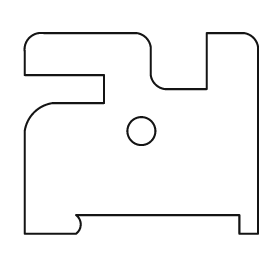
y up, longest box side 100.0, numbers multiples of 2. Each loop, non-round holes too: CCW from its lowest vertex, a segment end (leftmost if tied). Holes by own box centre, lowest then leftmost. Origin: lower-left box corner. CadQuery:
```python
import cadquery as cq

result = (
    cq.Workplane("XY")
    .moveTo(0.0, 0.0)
    .lineTo(22.0, 0.0)
    .threePointArc((24.0, 4.0), (22.0, 8.0))
    .lineTo(92.0, 8.0)
    .lineTo(92.0, 0.0)
    .lineTo(100.0, 0.0)
    .lineTo(100.0, 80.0)
    .threePointArc((98.0, 84.0), (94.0, 86.0))
    .lineTo(78.0, 86.0)
    .lineTo(78.0, 62.0)
    .lineTo(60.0, 62.0)
    .threePointArc((56.0, 64.0), (54.0, 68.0))
    .lineTo(54.0, 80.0)
    .threePointArc((52.0, 84.0), (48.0, 86.0))
    .lineTo(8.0, 86.0)
    .threePointArc((2.0, 84.0), (0.0, 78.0))
    .lineTo(0.0, 68.0)
    .lineTo(34.0, 68.0)
    .lineTo(34.0, 56.0)
    .lineTo(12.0, 56.0)
    .threePointArc((4.0, 52.0), (0.0, 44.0))
    .close()
    .moveTo(50.0, 44.0)
    .circle(6.0)
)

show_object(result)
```